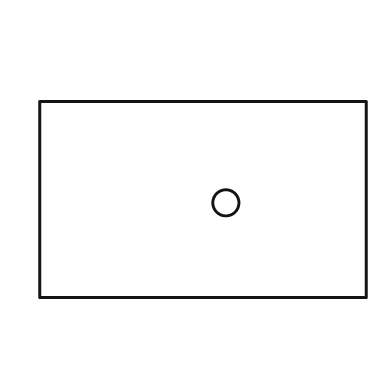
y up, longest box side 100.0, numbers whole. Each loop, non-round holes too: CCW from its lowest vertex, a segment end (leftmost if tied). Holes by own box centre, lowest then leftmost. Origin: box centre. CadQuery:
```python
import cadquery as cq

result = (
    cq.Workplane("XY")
    .moveTo(-50.0, -30.0)
    .lineTo(50.0, -30.0)
    .lineTo(50.0, 30.0)
    .lineTo(-50.0, 30.0)
    .close()
    .moveTo(7.0, -1.0)
    .circle(4.0)
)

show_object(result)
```